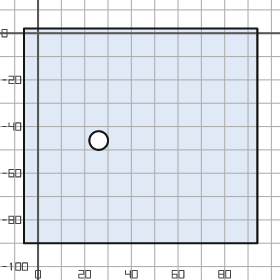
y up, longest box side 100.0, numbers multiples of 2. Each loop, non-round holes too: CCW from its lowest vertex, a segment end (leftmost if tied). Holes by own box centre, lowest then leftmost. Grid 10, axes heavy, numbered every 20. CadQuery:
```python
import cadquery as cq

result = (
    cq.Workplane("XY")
    .moveTo(-6.0, -90.0)
    .lineTo(94.0, -90.0)
    .lineTo(94.0, 2.0)
    .lineTo(-6.0, 2.0)
    .close()
    .moveTo(26.0, -46.0)
    .circle(4.0)
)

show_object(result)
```